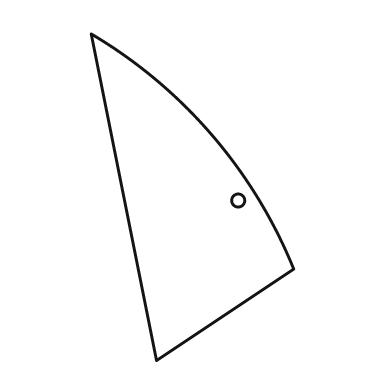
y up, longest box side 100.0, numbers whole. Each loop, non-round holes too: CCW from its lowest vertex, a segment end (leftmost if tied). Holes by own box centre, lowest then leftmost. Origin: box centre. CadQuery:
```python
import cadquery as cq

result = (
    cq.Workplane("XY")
    .moveTo(-11.0, -50.0)
    .lineTo(31.0, -22.0)
    .threePointArc((6.0, 19.0), (-31.0, 50.0))
    .close()
    .moveTo(14.0, -1.0)
    .circle(2.0)
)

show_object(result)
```